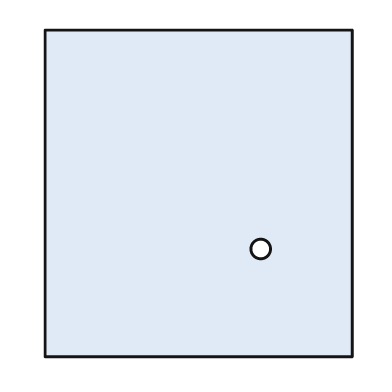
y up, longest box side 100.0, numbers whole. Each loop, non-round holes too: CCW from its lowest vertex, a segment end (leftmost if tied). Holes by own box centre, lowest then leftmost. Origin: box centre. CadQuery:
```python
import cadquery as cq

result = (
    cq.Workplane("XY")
    .moveTo(-47.0, -50.0)
    .lineTo(47.0, -50.0)
    .lineTo(47.0, 50.0)
    .lineTo(-47.0, 50.0)
    .close()
    .moveTo(19.0, -17.0)
    .circle(3.0)
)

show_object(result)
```